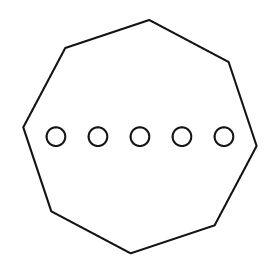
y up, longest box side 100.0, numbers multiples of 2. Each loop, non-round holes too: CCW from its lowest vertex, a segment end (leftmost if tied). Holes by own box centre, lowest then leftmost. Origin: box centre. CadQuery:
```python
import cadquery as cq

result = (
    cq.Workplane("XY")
    .moveTo(-4.0, -50.0)
    .lineTo(32.0, -38.0)
    .lineTo(50.0, -4.0)
    .lineTo(38.0, 32.0)
    .lineTo(4.0, 50.0)
    .lineTo(-32.0, 38.0)
    .lineTo(-50.0, 4.0)
    .lineTo(-38.0, -32.0)
    .close()
    .moveTo(-36.0, 0.0)
    .circle(4.0)
    .moveTo(-18.0, 0.0)
    .circle(4.0)
    .moveTo(0.0, 0.0)
    .circle(4.0)
    .moveTo(18.0, 0.0)
    .circle(4.0)
    .moveTo(36.0, 0.0)
    .circle(4.0)
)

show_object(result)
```